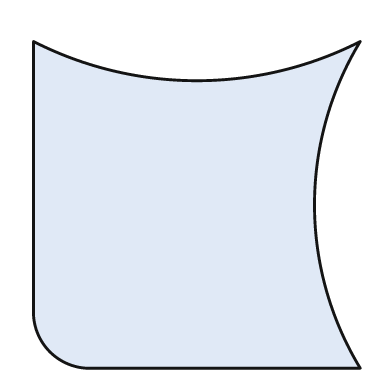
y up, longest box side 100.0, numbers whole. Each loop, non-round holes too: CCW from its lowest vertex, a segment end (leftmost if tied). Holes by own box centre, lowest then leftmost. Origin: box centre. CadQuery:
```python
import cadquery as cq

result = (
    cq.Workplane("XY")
    .moveTo(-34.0, -50.0)
    .lineTo(50.0, -50.0)
    .threePointArc((36.0, 0.0), (50.0, 50.0))
    .threePointArc((0.0, 38.0), (-50.0, 50.0))
    .lineTo(-50.0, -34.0)
    .threePointArc((-45.0, -45.0), (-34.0, -50.0))
    .close()
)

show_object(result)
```